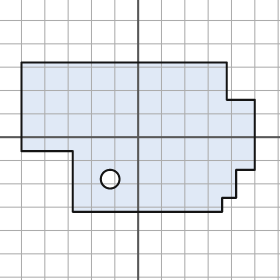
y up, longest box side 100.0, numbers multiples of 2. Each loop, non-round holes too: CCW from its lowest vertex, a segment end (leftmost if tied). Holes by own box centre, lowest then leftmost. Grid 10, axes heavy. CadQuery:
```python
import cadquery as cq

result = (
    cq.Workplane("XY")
    .moveTo(-28.0, -32.0)
    .lineTo(36.0, -32.0)
    .lineTo(36.0, -26.0)
    .lineTo(42.0, -26.0)
    .lineTo(42.0, -14.0)
    .lineTo(50.0, -14.0)
    .lineTo(50.0, 16.0)
    .lineTo(38.0, 16.0)
    .lineTo(38.0, 32.0)
    .lineTo(-50.0, 32.0)
    .lineTo(-50.0, -6.0)
    .lineTo(-28.0, -6.0)
    .close()
    .moveTo(-12.0, -18.0)
    .circle(4.0)
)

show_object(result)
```